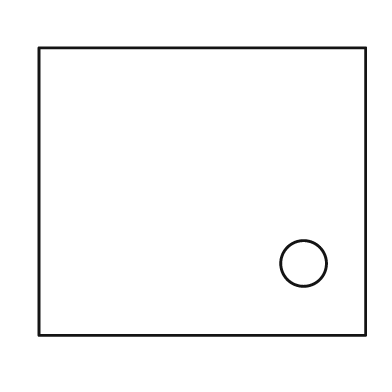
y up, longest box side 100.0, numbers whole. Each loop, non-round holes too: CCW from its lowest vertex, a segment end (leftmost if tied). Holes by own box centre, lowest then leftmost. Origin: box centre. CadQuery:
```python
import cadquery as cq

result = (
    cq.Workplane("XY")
    .moveTo(-50.0, -44.0)
    .lineTo(50.0, -44.0)
    .lineTo(50.0, 44.0)
    .lineTo(-50.0, 44.0)
    .close()
    .moveTo(31.0, -22.0)
    .circle(7.0)
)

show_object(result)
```